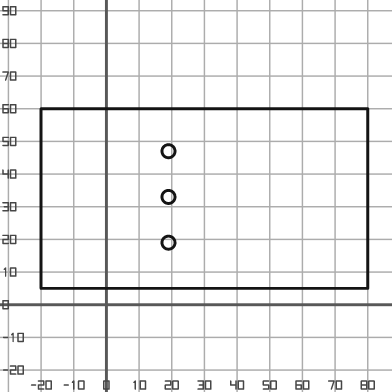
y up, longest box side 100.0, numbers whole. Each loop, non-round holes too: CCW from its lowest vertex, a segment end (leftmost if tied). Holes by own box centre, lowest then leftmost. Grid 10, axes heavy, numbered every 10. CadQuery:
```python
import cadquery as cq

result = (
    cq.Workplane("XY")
    .moveTo(-20.0, 5.0)
    .lineTo(80.0, 5.0)
    .lineTo(80.0, 60.0)
    .lineTo(-20.0, 60.0)
    .close()
    .moveTo(19.0, 19.0)
    .circle(2.0)
    .moveTo(19.0, 33.0)
    .circle(2.0)
    .moveTo(19.0, 47.0)
    .circle(2.0)
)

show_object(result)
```